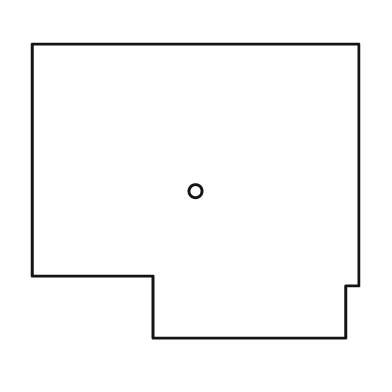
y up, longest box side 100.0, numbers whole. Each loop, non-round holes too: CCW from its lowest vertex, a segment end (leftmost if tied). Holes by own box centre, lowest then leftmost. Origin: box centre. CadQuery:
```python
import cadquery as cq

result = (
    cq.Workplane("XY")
    .moveTo(-13.0, -45.0)
    .lineTo(46.0, -45.0)
    .lineTo(46.0, -29.0)
    .lineTo(50.0, -29.0)
    .lineTo(50.0, 45.0)
    .lineTo(-50.0, 45.0)
    .lineTo(-50.0, -26.0)
    .lineTo(-13.0, -26.0)
    .close()
    .moveTo(0.0, 0.0)
    .circle(2.0)
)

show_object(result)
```